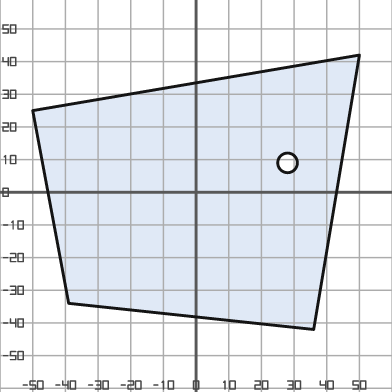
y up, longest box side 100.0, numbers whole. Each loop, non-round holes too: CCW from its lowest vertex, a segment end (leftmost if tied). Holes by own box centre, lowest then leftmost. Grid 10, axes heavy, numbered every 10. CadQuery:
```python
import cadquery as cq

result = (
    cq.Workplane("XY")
    .moveTo(36.0, -42.0)
    .lineTo(50.0, 42.0)
    .lineTo(-50.0, 25.0)
    .lineTo(-39.0, -34.0)
    .close()
    .moveTo(28.0, 9.0)
    .circle(3.0)
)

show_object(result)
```